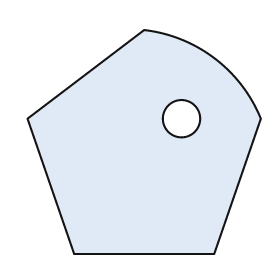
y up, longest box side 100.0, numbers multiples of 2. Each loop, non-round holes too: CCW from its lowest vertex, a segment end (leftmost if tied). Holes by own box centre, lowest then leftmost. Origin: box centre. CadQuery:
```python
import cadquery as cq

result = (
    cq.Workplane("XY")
    .moveTo(-30.0, -48.0)
    .lineTo(30.0, -48.0)
    .lineTo(50.0, 10.0)
    .threePointArc((30.0, 36.0), (0.0, 48.0))
    .lineTo(-50.0, 10.0)
    .close()
    .moveTo(16.0, 10.0)
    .circle(8.0)
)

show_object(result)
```